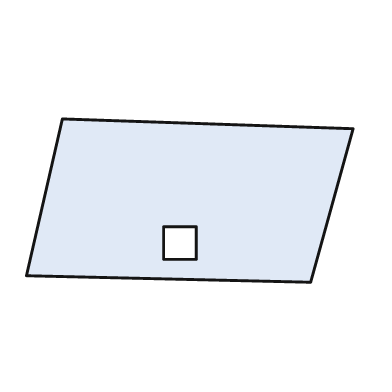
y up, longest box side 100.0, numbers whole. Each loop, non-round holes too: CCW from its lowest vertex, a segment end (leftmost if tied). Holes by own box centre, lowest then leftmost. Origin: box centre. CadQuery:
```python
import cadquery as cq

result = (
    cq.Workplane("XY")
    .moveTo(37.0, -25.0)
    .lineTo(50.0, 22.0)
    .lineTo(-39.0, 25.0)
    .lineTo(-50.0, -23.0)
    .close()
    .moveTo(-8.0, -18.0)
    .lineTo(2.0, -18.0)
    .lineTo(2.0, -8.0)
    .lineTo(-8.0, -8.0)
    .close()
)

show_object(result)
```